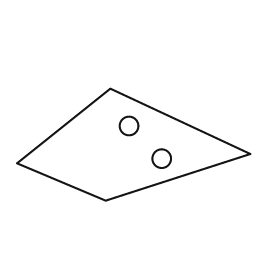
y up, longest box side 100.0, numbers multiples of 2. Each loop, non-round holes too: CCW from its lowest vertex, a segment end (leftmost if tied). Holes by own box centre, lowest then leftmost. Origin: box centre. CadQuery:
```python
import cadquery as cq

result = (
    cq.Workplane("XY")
    .moveTo(-12.0, -24.0)
    .lineTo(50.0, -4.0)
    .lineTo(-10.0, 24.0)
    .lineTo(-50.0, -8.0)
    .close()
    .moveTo(12.0, -6.0)
    .circle(4.0)
    .moveTo(-2.0, 8.0)
    .circle(4.0)
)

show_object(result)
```